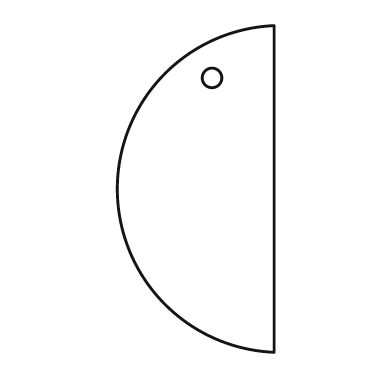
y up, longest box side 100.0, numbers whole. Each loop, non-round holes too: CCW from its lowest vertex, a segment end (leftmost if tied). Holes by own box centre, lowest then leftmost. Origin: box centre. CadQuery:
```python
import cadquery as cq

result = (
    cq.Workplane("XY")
    .moveTo(24.0, -50.0)
    .lineTo(24.0, 50.0)
    .threePointArc((-24.0, 0.0), (24.0, -50.0))
    .close()
    .moveTo(5.0, 34.0)
    .circle(3.0)
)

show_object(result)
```